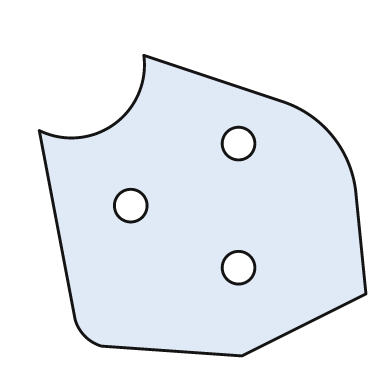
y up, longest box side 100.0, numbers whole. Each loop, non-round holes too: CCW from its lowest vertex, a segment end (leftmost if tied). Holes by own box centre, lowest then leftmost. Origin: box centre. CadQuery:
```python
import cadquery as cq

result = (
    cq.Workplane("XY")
    .moveTo(12.0, -46.0)
    .lineTo(50.0, -27.0)
    .lineTo(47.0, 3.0)
    .threePointArc((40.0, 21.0), (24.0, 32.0))
    .lineTo(-18.0, 46.0)
    .threePointArc((-27.0, 25.0), (-50.0, 23.0))
    .lineTo(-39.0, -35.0)
    .threePointArc((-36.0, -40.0), (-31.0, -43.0))
    .close()
    .moveTo(11.0, -19.0)
    .circle(5.0)
    .moveTo(-22.0, 0.0)
    .circle(5.0)
    .moveTo(11.0, 19.0)
    .circle(5.0)
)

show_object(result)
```